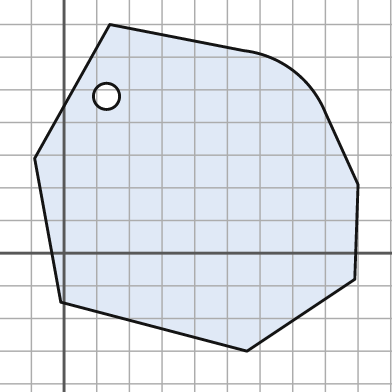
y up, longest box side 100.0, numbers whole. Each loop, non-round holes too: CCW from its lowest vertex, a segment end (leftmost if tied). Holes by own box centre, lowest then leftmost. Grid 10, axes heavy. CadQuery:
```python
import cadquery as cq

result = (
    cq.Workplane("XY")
    .moveTo(56.0, -30.0)
    .lineTo(89.0, -8.0)
    .lineTo(90.0, 21.0)
    .lineTo(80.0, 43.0)
    .threePointArc((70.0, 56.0), (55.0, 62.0))
    .lineTo(14.0, 70.0)
    .lineTo(-9.0, 29.0)
    .lineTo(-1.0, -15.0)
    .close()
    .moveTo(13.0, 48.0)
    .circle(4.0)
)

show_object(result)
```